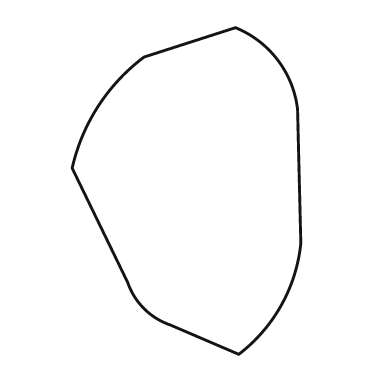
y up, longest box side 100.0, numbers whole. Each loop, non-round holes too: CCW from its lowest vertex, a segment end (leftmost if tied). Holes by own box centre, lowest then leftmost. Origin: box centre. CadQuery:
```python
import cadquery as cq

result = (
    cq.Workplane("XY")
    .moveTo(16.0, -50.0)
    .threePointArc((29.0, -35.0), (35.0, -16.0))
    .lineTo(34.0, 25.0)
    .threePointArc((28.0, 40.0), (15.0, 50.0))
    .lineTo(-13.0, 41.0)
    .threePointArc((-27.0, 26.0), (-35.0, 7.0))
    .lineTo(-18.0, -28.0)
    .threePointArc((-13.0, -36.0), (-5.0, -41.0))
    .close()
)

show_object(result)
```